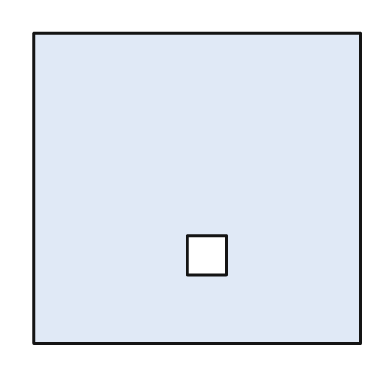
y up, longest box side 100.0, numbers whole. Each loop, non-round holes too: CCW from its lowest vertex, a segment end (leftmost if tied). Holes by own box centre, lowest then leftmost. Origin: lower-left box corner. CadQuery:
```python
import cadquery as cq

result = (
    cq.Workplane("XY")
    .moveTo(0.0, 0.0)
    .lineTo(100.0, 0.0)
    .lineTo(100.0, 95.0)
    .lineTo(0.0, 95.0)
    .close()
    .moveTo(47.0, 21.0)
    .lineTo(59.0, 21.0)
    .lineTo(59.0, 33.0)
    .lineTo(47.0, 33.0)
    .close()
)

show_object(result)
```